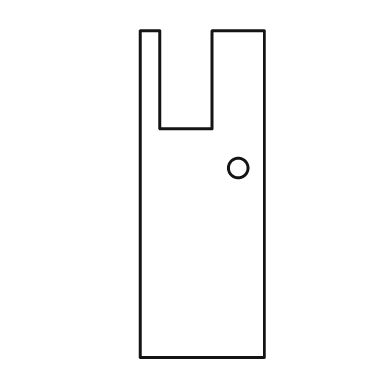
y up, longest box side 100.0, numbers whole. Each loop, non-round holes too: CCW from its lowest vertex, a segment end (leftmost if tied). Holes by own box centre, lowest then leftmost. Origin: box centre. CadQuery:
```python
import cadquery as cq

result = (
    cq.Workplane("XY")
    .moveTo(-19.0, -50.0)
    .lineTo(19.0, -50.0)
    .lineTo(19.0, 50.0)
    .lineTo(3.0, 50.0)
    .lineTo(3.0, 20.0)
    .lineTo(-13.0, 20.0)
    .lineTo(-13.0, 50.0)
    .lineTo(-19.0, 50.0)
    .close()
    .moveTo(11.0, 8.0)
    .circle(3.0)
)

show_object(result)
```